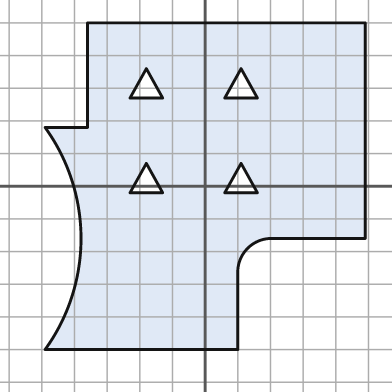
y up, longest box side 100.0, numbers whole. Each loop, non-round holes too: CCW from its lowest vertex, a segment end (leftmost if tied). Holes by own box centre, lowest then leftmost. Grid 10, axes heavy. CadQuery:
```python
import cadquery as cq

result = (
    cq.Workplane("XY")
    .moveTo(-49.0, -50.0)
    .lineTo(10.0, -50.0)
    .lineTo(10.0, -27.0)
    .threePointArc((13.0, -19.0), (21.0, -16.0))
    .lineTo(49.0, -16.0)
    .lineTo(49.0, 50.0)
    .lineTo(-36.0, 50.0)
    .lineTo(-36.0, 18.0)
    .lineTo(-49.0, 18.0)
    .threePointArc((-38.0, -16.0), (-49.0, -50.0))
    .close()
    .moveTo(-23.0, -2.0)
    .lineTo(-13.0, -2.0)
    .lineTo(-18.0, 7.0)
    .close()
    .moveTo(6.0, -2.0)
    .lineTo(16.0, -2.0)
    .lineTo(11.0, 7.0)
    .close()
    .moveTo(-23.0, 27.0)
    .lineTo(-13.0, 27.0)
    .lineTo(-18.0, 36.0)
    .close()
    .moveTo(6.0, 27.0)
    .lineTo(16.0, 27.0)
    .lineTo(11.0, 36.0)
    .close()
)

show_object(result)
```